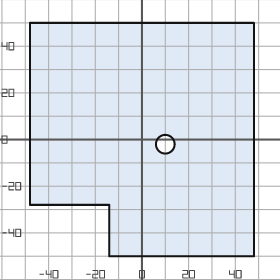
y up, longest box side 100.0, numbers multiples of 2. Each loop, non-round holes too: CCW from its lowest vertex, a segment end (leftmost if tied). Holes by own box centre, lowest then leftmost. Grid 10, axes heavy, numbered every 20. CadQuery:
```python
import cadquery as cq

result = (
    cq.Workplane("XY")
    .moveTo(-14.0, -50.0)
    .lineTo(48.0, -50.0)
    .lineTo(48.0, 50.0)
    .lineTo(-48.0, 50.0)
    .lineTo(-48.0, -28.0)
    .lineTo(-14.0, -28.0)
    .close()
    .moveTo(10.0, -2.0)
    .circle(4.0)
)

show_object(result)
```